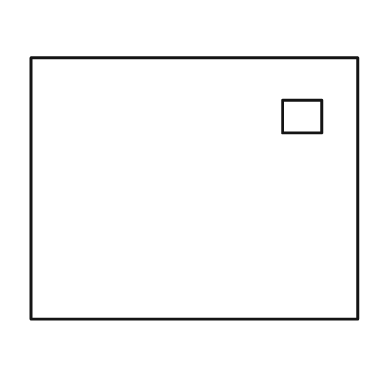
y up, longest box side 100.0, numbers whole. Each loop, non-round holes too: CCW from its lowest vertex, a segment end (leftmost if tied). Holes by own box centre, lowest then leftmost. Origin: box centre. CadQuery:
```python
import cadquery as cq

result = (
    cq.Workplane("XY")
    .moveTo(-50.0, -40.0)
    .lineTo(50.0, -40.0)
    .lineTo(50.0, 40.0)
    .lineTo(-50.0, 40.0)
    .close()
    .moveTo(27.0, 17.0)
    .lineTo(39.0, 17.0)
    .lineTo(39.0, 27.0)
    .lineTo(27.0, 27.0)
    .close()
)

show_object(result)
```